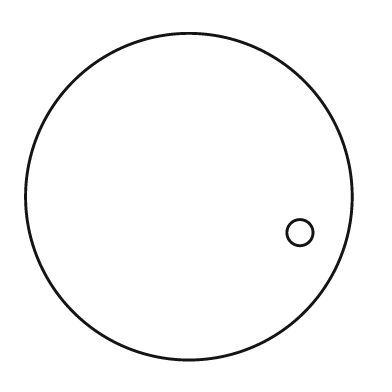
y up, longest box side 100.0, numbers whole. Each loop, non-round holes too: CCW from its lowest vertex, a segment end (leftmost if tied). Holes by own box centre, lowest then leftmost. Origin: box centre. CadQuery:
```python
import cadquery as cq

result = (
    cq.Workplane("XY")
    .moveTo(0.0, 0.0)
    .circle(50.0)
    .moveTo(34.0, -11.0)
    .circle(4.0)
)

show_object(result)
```